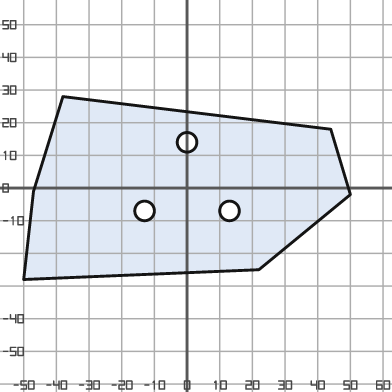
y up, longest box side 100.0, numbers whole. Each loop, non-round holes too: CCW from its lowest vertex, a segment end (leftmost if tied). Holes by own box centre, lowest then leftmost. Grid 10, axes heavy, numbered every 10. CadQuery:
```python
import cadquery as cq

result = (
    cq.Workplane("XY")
    .moveTo(-50.0, -28.0)
    .lineTo(22.0, -25.0)
    .lineTo(50.0, -2.0)
    .lineTo(44.0, 18.0)
    .lineTo(-38.0, 28.0)
    .lineTo(-47.0, -1.0)
    .close()
    .moveTo(-13.0, -7.0)
    .circle(3.0)
    .moveTo(13.0, -7.0)
    .circle(3.0)
    .moveTo(0.0, 14.0)
    .circle(3.0)
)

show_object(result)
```